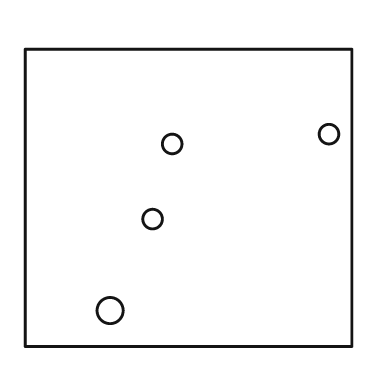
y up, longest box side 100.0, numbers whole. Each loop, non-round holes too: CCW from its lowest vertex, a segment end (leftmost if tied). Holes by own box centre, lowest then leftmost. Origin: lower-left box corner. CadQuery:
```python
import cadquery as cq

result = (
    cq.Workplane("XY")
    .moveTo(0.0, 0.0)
    .lineTo(100.0, 0.0)
    .lineTo(100.0, 91.0)
    .lineTo(0.0, 91.0)
    .close()
    .moveTo(26.0, 11.0)
    .circle(4.0)
    .moveTo(39.0, 39.0)
    .circle(3.0)
    .moveTo(45.0, 62.0)
    .circle(3.0)
    .moveTo(93.0, 65.0)
    .circle(3.0)
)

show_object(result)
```